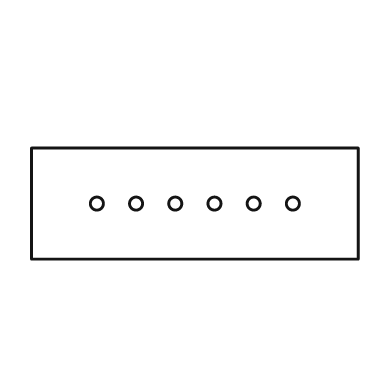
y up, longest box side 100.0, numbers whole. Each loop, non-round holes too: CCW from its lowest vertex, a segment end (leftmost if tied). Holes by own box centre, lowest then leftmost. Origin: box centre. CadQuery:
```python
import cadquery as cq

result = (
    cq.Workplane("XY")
    .moveTo(-50.0, -17.0)
    .lineTo(50.0, -17.0)
    .lineTo(50.0, 17.0)
    .lineTo(-50.0, 17.0)
    .close()
    .moveTo(-30.0, 0.0)
    .circle(2.0)
    .moveTo(-18.0, 0.0)
    .circle(2.0)
    .moveTo(-6.0, 0.0)
    .circle(2.0)
    .moveTo(6.0, 0.0)
    .circle(2.0)
    .moveTo(18.0, 0.0)
    .circle(2.0)
    .moveTo(30.0, 0.0)
    .circle(2.0)
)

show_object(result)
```